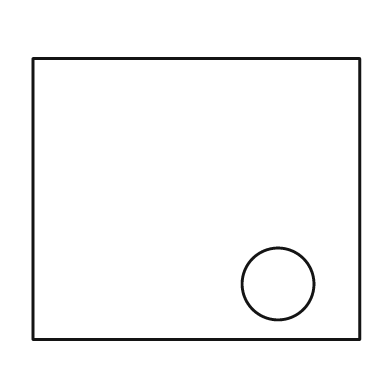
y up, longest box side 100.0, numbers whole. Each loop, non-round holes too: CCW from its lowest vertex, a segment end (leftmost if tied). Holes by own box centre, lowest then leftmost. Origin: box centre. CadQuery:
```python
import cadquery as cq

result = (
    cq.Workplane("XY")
    .moveTo(-50.0, -43.0)
    .lineTo(50.0, -43.0)
    .lineTo(50.0, 43.0)
    .lineTo(-50.0, 43.0)
    .close()
    .moveTo(25.0, -26.0)
    .circle(11.0)
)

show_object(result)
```